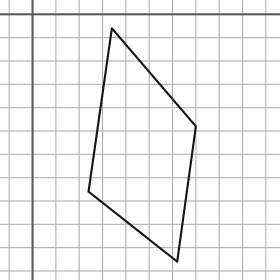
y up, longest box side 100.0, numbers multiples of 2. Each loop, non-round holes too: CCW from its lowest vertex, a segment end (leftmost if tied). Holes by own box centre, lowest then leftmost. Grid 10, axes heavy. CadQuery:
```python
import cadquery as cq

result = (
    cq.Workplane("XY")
    .moveTo(62.0, -106.0)
    .lineTo(70.0, -48.0)
    .lineTo(34.0, -6.0)
    .lineTo(24.0, -76.0)
    .close()
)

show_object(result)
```